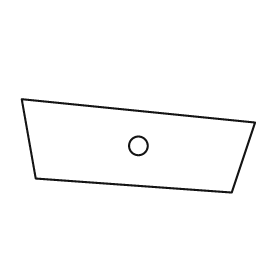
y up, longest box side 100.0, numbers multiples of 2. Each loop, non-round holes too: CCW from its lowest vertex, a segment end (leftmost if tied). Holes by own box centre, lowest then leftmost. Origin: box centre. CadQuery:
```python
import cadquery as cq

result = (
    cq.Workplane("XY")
    .moveTo(40.0, -20.0)
    .lineTo(50.0, 10.0)
    .lineTo(-50.0, 20.0)
    .lineTo(-44.0, -14.0)
    .close()
    .moveTo(0.0, 0.0)
    .circle(4.0)
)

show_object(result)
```